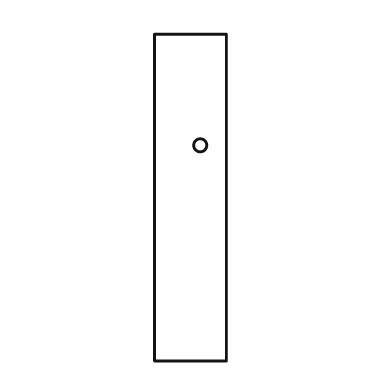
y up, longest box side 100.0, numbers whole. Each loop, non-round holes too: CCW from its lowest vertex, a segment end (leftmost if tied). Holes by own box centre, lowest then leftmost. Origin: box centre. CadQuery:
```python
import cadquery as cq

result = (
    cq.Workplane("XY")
    .moveTo(-11.0, -50.0)
    .lineTo(11.0, -50.0)
    .lineTo(11.0, 50.0)
    .lineTo(-11.0, 50.0)
    .close()
    .moveTo(3.0, 16.0)
    .circle(2.0)
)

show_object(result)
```